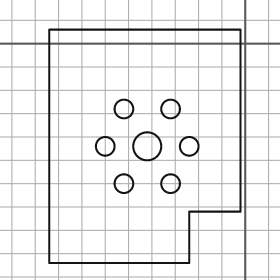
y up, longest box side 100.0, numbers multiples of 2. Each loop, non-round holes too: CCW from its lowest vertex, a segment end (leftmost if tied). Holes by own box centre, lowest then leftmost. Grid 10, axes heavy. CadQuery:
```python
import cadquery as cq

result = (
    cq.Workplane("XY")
    .moveTo(-84.0, -94.0)
    .lineTo(-24.0, -94.0)
    .lineTo(-24.0, -72.0)
    .lineTo(-2.0, -72.0)
    .lineTo(-2.0, 6.0)
    .lineTo(-84.0, 6.0)
    .close()
    .moveTo(-52.0, -60.0)
    .circle(4.0)
    .moveTo(-32.0, -60.0)
    .circle(4.0)
    .moveTo(-60.0, -44.0)
    .circle(4.0)
    .moveTo(-42.0, -44.0)
    .circle(6.0)
    .moveTo(-24.0, -44.0)
    .circle(4.0)
    .moveTo(-52.0, -28.0)
    .circle(4.0)
    .moveTo(-32.0, -28.0)
    .circle(4.0)
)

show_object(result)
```